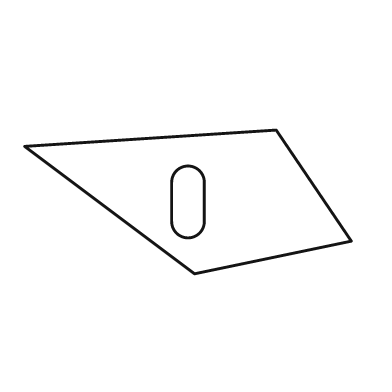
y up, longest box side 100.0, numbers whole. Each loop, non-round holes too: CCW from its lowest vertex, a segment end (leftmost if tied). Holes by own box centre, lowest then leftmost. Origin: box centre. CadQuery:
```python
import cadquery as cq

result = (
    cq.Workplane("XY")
    .moveTo(2.0, -22.0)
    .lineTo(50.0, -12.0)
    .lineTo(27.0, 22.0)
    .lineTo(-50.0, 17.0)
    .close()
    .moveTo(-5.0, -6.0)
    .threePointArc((0.0, -11.0), (5.0, -6.0))
    .lineTo(5.0, 6.0)
    .threePointArc((0.0, 11.0), (-5.0, 6.0))
    .close()
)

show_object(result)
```